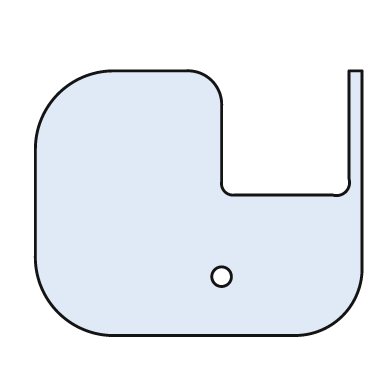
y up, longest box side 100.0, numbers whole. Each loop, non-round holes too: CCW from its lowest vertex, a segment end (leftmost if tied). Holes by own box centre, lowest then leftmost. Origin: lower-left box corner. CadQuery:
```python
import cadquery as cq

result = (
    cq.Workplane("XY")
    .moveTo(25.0, 0.0)
    .lineTo(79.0, 0.0)
    .threePointArc((94.0, 6.0), (100.0, 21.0))
    .lineTo(100.0, 81.0)
    .lineTo(96.0, 81.0)
    .lineTo(96.0, 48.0)
    .threePointArc((95.0, 44.0), (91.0, 43.0))
    .lineTo(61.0, 43.0)
    .threePointArc((58.0, 44.0), (57.0, 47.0))
    .lineTo(57.0, 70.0)
    .threePointArc((54.0, 78.0), (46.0, 81.0))
    .lineTo(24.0, 81.0)
    .threePointArc((7.0, 74.0), (0.0, 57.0))
    .lineTo(0.0, 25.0)
    .threePointArc((7.0, 7.0), (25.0, 0.0))
    .close()
    .moveTo(57.0, 18.0)
    .circle(3.0)
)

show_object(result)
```